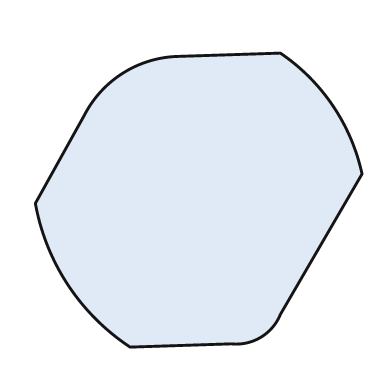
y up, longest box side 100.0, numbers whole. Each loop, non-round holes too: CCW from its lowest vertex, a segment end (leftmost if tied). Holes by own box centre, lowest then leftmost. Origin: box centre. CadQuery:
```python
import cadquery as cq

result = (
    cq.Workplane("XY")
    .moveTo(-21.0, -45.0)
    .lineTo(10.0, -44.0)
    .threePointArc((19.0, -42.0), (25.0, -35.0))
    .lineTo(50.0, 8.0)
    .threePointArc((41.0, 29.0), (25.0, 45.0))
    .lineTo(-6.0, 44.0)
    .threePointArc((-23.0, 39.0), (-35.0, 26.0))
    .lineTo(-50.0, -1.0)
    .threePointArc((-40.0, -26.0), (-21.0, -45.0))
    .close()
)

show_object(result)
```